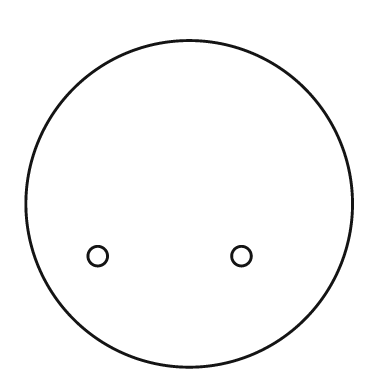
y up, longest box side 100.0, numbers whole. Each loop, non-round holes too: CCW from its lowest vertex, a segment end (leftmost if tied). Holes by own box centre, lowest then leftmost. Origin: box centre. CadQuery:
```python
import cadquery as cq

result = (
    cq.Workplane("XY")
    .moveTo(0.0, 0.0)
    .circle(50.0)
    .moveTo(-28.0, -16.0)
    .circle(3.0)
    .moveTo(16.0, -16.0)
    .circle(3.0)
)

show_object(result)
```